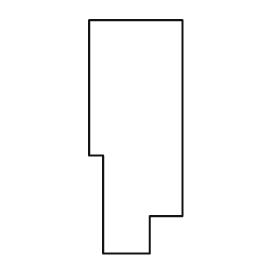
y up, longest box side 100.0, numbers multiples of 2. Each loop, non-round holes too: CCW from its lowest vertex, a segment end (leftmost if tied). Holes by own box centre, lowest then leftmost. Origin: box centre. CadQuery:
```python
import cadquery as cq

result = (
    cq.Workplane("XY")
    .moveTo(-14.0, -50.0)
    .lineTo(6.0, -50.0)
    .lineTo(6.0, -34.0)
    .lineTo(20.0, -34.0)
    .lineTo(20.0, 50.0)
    .lineTo(-20.0, 50.0)
    .lineTo(-20.0, -8.0)
    .lineTo(-14.0, -8.0)
    .close()
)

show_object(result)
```